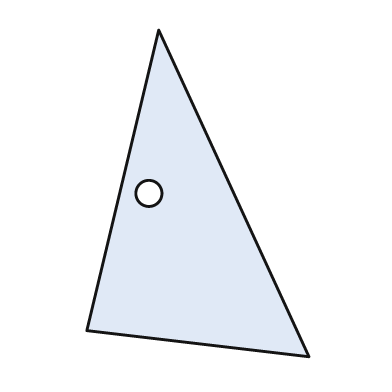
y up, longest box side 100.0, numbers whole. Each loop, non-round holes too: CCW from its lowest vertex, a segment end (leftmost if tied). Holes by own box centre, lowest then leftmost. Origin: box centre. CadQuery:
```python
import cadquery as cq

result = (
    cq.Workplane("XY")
    .moveTo(34.0, -50.0)
    .lineTo(-12.0, 50.0)
    .lineTo(-34.0, -42.0)
    .close()
    .moveTo(-15.0, 0.0)
    .circle(4.0)
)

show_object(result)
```